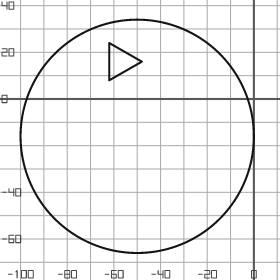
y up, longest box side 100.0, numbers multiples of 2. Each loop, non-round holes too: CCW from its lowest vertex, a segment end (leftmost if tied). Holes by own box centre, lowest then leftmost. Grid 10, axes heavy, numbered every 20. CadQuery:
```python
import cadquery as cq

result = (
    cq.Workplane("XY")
    .moveTo(-50.0, -16.0)
    .circle(50.0)
    .moveTo(-62.0, 8.0)
    .lineTo(-48.0, 16.0)
    .lineTo(-62.0, 24.0)
    .close()
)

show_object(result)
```